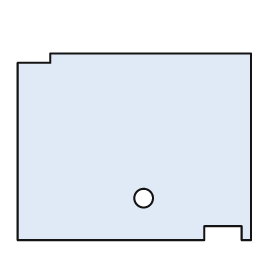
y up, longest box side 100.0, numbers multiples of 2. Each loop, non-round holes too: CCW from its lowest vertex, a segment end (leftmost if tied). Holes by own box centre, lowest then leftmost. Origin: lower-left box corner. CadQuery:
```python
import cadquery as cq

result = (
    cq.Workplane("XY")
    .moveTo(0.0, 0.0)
    .lineTo(80.0, 0.0)
    .lineTo(80.0, 6.0)
    .lineTo(96.0, 6.0)
    .lineTo(96.0, 0.0)
    .lineTo(100.0, 0.0)
    .lineTo(100.0, 80.0)
    .lineTo(14.0, 80.0)
    .lineTo(14.0, 76.0)
    .lineTo(0.0, 76.0)
    .close()
    .moveTo(54.0, 18.0)
    .circle(4.0)
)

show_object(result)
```